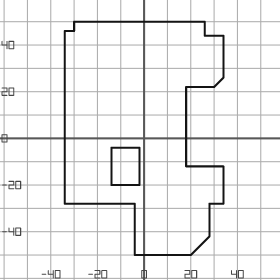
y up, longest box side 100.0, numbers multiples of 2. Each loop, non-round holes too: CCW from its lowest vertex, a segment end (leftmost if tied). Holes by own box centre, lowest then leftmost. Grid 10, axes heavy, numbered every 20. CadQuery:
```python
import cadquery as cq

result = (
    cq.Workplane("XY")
    .moveTo(-4.0, -50.0)
    .lineTo(20.0, -50.0)
    .lineTo(28.0, -42.0)
    .lineTo(28.0, -28.0)
    .lineTo(34.0, -28.0)
    .lineTo(34.0, -12.0)
    .lineTo(18.0, -12.0)
    .lineTo(18.0, 22.0)
    .lineTo(30.0, 22.0)
    .lineTo(34.0, 26.0)
    .lineTo(34.0, 44.0)
    .lineTo(26.0, 44.0)
    .lineTo(26.0, 50.0)
    .lineTo(-30.0, 50.0)
    .lineTo(-30.0, 46.0)
    .lineTo(-34.0, 46.0)
    .lineTo(-34.0, -28.0)
    .lineTo(-4.0, -28.0)
    .close()
    .moveTo(-14.0, -20.0)
    .lineTo(-2.0, -20.0)
    .lineTo(-2.0, -4.0)
    .lineTo(-14.0, -4.0)
    .close()
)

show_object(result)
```